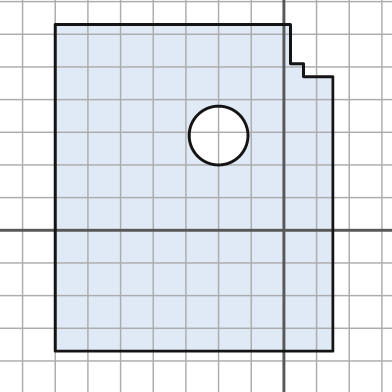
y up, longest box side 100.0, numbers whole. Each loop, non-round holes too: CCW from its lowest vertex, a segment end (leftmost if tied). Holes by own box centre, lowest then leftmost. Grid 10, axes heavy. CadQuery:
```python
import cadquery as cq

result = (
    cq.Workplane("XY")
    .moveTo(-70.0, -37.0)
    .lineTo(15.0, -37.0)
    .lineTo(15.0, 47.0)
    .lineTo(6.0, 47.0)
    .lineTo(6.0, 51.0)
    .lineTo(2.0, 51.0)
    .lineTo(2.0, 63.0)
    .lineTo(-70.0, 63.0)
    .close()
    .moveTo(-20.0, 29.0)
    .circle(9.0)
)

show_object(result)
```